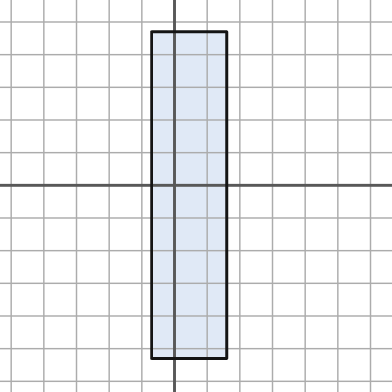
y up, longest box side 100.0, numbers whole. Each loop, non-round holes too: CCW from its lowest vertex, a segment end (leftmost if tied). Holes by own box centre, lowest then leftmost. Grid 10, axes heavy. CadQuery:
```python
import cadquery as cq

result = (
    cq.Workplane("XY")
    .moveTo(-7.0, -53.0)
    .lineTo(16.0, -53.0)
    .lineTo(16.0, 47.0)
    .lineTo(-7.0, 47.0)
    .close()
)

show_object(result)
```